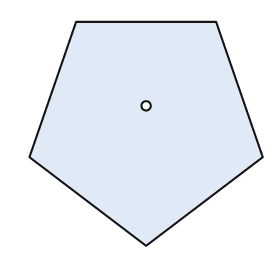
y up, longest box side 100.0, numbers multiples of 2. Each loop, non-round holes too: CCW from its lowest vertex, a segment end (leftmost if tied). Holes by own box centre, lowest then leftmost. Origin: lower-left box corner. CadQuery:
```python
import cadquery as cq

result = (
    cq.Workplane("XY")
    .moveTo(50.0, 0.0)
    .lineTo(100.0, 38.0)
    .lineTo(80.0, 96.0)
    .lineTo(20.0, 96.0)
    .lineTo(0.0, 38.0)
    .close()
    .moveTo(50.0, 60.0)
    .circle(2.0)
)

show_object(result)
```